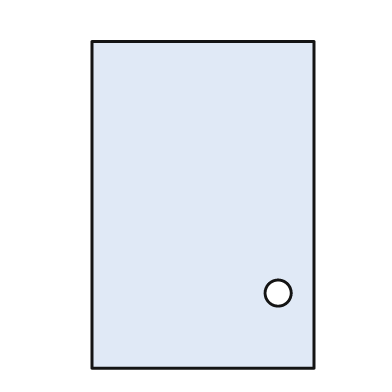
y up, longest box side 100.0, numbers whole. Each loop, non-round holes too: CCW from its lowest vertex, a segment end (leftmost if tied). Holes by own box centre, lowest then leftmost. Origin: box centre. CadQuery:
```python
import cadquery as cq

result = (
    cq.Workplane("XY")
    .moveTo(-34.0, -50.0)
    .lineTo(34.0, -50.0)
    .lineTo(34.0, 50.0)
    .lineTo(-34.0, 50.0)
    .close()
    .moveTo(23.0, -27.0)
    .circle(4.0)
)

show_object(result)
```